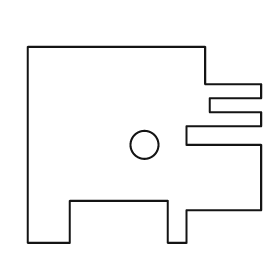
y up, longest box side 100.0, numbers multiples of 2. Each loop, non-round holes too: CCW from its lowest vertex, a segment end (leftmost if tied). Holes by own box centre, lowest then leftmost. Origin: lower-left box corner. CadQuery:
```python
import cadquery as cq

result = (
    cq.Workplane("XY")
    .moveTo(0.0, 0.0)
    .lineTo(18.0, 0.0)
    .lineTo(18.0, 18.0)
    .lineTo(60.0, 18.0)
    .lineTo(60.0, 0.0)
    .lineTo(68.0, 0.0)
    .lineTo(68.0, 14.0)
    .lineTo(100.0, 14.0)
    .lineTo(100.0, 42.0)
    .lineTo(68.0, 42.0)
    .lineTo(68.0, 50.0)
    .lineTo(100.0, 50.0)
    .lineTo(100.0, 56.0)
    .lineTo(78.0, 56.0)
    .lineTo(78.0, 62.0)
    .lineTo(100.0, 62.0)
    .lineTo(100.0, 68.0)
    .lineTo(76.0, 68.0)
    .lineTo(76.0, 84.0)
    .lineTo(0.0, 84.0)
    .close()
    .moveTo(50.0, 42.0)
    .circle(6.0)
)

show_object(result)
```